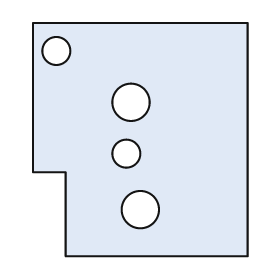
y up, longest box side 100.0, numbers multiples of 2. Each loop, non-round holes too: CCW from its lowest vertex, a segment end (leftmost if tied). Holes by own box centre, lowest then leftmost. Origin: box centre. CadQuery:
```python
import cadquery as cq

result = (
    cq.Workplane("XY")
    .moveTo(-32.0, -50.0)
    .lineTo(46.0, -50.0)
    .lineTo(46.0, 50.0)
    .lineTo(-46.0, 50.0)
    .lineTo(-46.0, -14.0)
    .lineTo(-32.0, -14.0)
    .close()
    .moveTo(0.0, -30.0)
    .circle(8.0)
    .moveTo(-6.0, -6.0)
    .circle(6.0)
    .moveTo(-4.0, 16.0)
    .circle(8.0)
    .moveTo(-36.0, 38.0)
    .circle(6.0)
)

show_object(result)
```